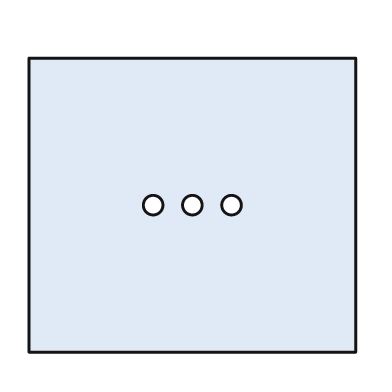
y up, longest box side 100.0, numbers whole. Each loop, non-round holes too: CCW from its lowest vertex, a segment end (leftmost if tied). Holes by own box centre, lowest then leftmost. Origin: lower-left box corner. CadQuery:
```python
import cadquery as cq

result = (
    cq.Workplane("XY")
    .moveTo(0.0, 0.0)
    .lineTo(100.0, 0.0)
    .lineTo(100.0, 90.0)
    .lineTo(0.0, 90.0)
    .close()
    .moveTo(38.0, 45.0)
    .circle(3.0)
    .moveTo(50.0, 45.0)
    .circle(3.0)
    .moveTo(62.0, 45.0)
    .circle(3.0)
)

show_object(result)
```